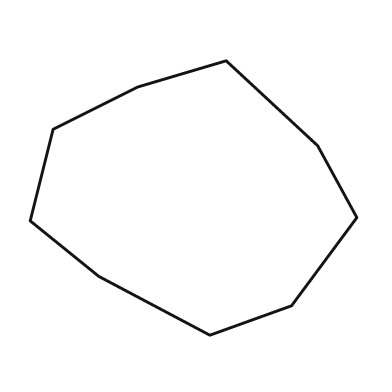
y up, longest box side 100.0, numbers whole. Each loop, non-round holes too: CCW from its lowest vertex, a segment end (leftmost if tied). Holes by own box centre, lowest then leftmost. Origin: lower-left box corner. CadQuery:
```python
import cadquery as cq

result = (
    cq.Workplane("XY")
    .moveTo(55.0, 0.0)
    .lineTo(80.0, 9.0)
    .lineTo(100.0, 36.0)
    .lineTo(88.0, 58.0)
    .lineTo(60.0, 84.0)
    .lineTo(33.0, 76.0)
    .lineTo(7.0, 63.0)
    .lineTo(0.0, 35.0)
    .lineTo(21.0, 18.0)
    .close()
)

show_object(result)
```